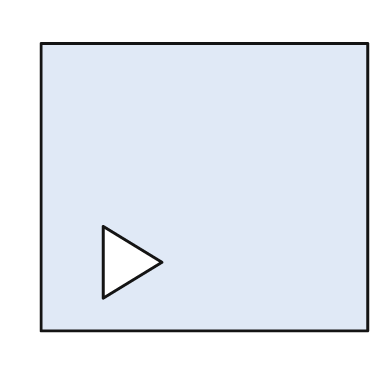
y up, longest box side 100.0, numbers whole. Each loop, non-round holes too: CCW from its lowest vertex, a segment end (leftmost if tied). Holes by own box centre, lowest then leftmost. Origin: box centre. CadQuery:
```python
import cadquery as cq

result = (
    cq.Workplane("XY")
    .moveTo(-50.0, -44.0)
    .lineTo(50.0, -44.0)
    .lineTo(50.0, 44.0)
    .lineTo(-50.0, 44.0)
    .close()
    .moveTo(-31.0, -34.0)
    .lineTo(-13.0, -23.0)
    .lineTo(-31.0, -12.0)
    .close()
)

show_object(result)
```